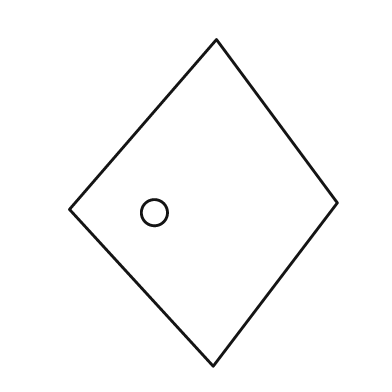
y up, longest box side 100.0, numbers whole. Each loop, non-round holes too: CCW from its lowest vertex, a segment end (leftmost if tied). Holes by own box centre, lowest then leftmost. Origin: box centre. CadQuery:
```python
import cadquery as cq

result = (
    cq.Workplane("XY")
    .moveTo(3.0, -50.0)
    .lineTo(41.0, 0.0)
    .lineTo(4.0, 50.0)
    .lineTo(-41.0, -2.0)
    .close()
    .moveTo(-15.0, -3.0)
    .circle(4.0)
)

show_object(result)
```